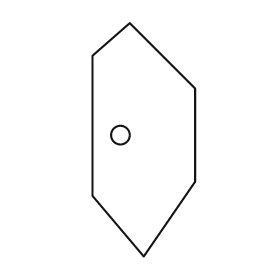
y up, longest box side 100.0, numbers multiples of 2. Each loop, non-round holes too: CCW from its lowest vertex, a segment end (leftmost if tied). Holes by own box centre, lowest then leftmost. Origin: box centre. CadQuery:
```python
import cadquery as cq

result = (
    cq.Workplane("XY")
    .moveTo(0.0, -50.0)
    .lineTo(22.0, -18.0)
    .lineTo(22.0, 22.0)
    .lineTo(-6.0, 50.0)
    .lineTo(-22.0, 36.0)
    .lineTo(-22.0, -24.0)
    .close()
    .moveTo(-10.0, 2.0)
    .circle(4.0)
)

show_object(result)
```